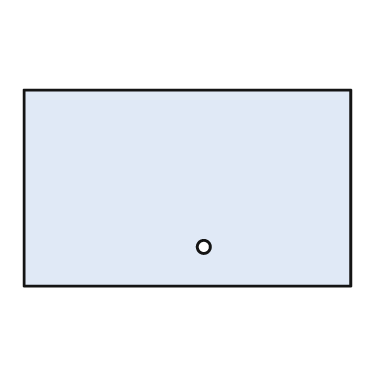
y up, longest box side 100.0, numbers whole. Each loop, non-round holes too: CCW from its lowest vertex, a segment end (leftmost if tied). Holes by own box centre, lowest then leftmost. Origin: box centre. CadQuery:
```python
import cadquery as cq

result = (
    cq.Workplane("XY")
    .moveTo(-50.0, -30.0)
    .lineTo(50.0, -30.0)
    .lineTo(50.0, 30.0)
    .lineTo(-50.0, 30.0)
    .close()
    .moveTo(5.0, -18.0)
    .circle(2.0)
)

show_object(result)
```